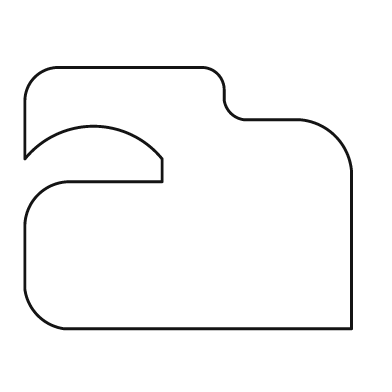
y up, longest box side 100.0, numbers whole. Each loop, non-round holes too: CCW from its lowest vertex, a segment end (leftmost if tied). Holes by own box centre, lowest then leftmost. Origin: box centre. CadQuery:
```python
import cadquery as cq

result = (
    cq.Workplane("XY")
    .moveTo(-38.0, -40.0)
    .lineTo(50.0, -40.0)
    .lineTo(50.0, 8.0)
    .threePointArc((45.0, 19.0), (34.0, 24.0))
    .lineTo(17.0, 24.0)
    .threePointArc((13.0, 26.0), (11.0, 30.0))
    .lineTo(11.0, 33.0)
    .threePointArc((9.0, 38.0), (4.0, 40.0))
    .lineTo(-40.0, 40.0)
    .threePointArc((-47.0, 37.0), (-50.0, 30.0))
    .lineTo(-50.0, 12.0)
    .threePointArc((-29.0, 22.0), (-8.0, 12.0))
    .lineTo(-8.0, 5.0)
    .lineTo(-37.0, 5.0)
    .threePointArc((-46.0, 1.0), (-50.0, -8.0))
    .lineTo(-50.0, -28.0)
    .threePointArc((-46.0, -36.0), (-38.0, -40.0))
    .close()
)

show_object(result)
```